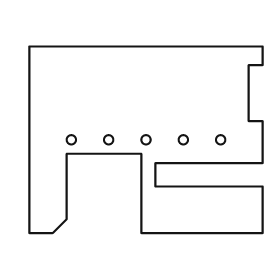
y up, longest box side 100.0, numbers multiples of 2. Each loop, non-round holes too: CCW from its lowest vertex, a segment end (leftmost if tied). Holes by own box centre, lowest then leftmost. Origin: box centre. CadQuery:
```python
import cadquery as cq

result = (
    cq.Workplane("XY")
    .moveTo(-50.0, -40.0)
    .lineTo(-40.0, -40.0)
    .lineTo(-34.0, -34.0)
    .lineTo(-34.0, -6.0)
    .lineTo(-2.0, -6.0)
    .lineTo(-2.0, -40.0)
    .lineTo(50.0, -40.0)
    .lineTo(50.0, -20.0)
    .lineTo(4.0, -20.0)
    .lineTo(4.0, -10.0)
    .lineTo(50.0, -10.0)
    .lineTo(50.0, 8.0)
    .lineTo(44.0, 8.0)
    .lineTo(44.0, 32.0)
    .lineTo(50.0, 32.0)
    .lineTo(50.0, 40.0)
    .lineTo(-50.0, 40.0)
    .close()
    .moveTo(-32.0, 0.0)
    .circle(2.0)
    .moveTo(-16.0, 0.0)
    .circle(2.0)
    .moveTo(0.0, 0.0)
    .circle(2.0)
    .moveTo(16.0, 0.0)
    .circle(2.0)
    .moveTo(32.0, 0.0)
    .circle(2.0)
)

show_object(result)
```